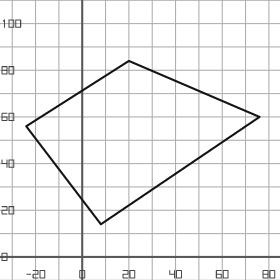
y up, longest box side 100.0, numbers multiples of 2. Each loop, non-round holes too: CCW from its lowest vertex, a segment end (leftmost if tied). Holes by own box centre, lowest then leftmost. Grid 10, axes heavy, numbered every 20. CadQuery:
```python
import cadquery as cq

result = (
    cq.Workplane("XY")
    .moveTo(8.0, 14.0)
    .lineTo(76.0, 60.0)
    .lineTo(20.0, 84.0)
    .lineTo(-24.0, 56.0)
    .close()
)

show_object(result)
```